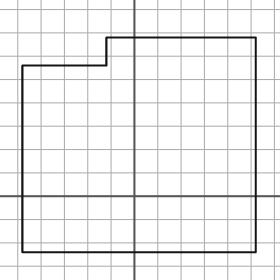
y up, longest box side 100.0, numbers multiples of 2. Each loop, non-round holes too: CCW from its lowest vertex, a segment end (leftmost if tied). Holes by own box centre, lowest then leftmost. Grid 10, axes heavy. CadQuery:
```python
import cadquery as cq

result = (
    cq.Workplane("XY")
    .moveTo(-48.0, -24.0)
    .lineTo(52.0, -24.0)
    .lineTo(52.0, 68.0)
    .lineTo(-12.0, 68.0)
    .lineTo(-12.0, 56.0)
    .lineTo(-48.0, 56.0)
    .close()
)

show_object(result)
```